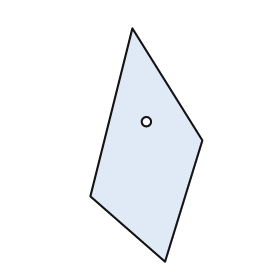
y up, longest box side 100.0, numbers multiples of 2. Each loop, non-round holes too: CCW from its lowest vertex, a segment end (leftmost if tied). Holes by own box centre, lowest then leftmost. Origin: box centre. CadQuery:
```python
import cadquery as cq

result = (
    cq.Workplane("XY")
    .moveTo(8.0, -50.0)
    .lineTo(24.0, 2.0)
    .lineTo(-6.0, 50.0)
    .lineTo(-24.0, -22.0)
    .close()
    .moveTo(0.0, 10.0)
    .circle(2.0)
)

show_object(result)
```